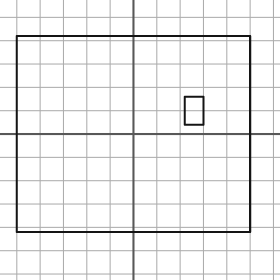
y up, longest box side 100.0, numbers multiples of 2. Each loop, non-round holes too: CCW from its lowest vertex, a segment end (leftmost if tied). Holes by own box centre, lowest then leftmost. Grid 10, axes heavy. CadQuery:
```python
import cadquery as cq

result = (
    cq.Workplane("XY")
    .moveTo(-50.0, -42.0)
    .lineTo(50.0, -42.0)
    .lineTo(50.0, 42.0)
    .lineTo(-50.0, 42.0)
    .close()
    .moveTo(22.0, 4.0)
    .lineTo(30.0, 4.0)
    .lineTo(30.0, 16.0)
    .lineTo(22.0, 16.0)
    .close()
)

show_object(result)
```